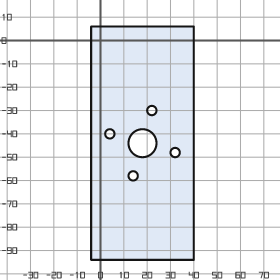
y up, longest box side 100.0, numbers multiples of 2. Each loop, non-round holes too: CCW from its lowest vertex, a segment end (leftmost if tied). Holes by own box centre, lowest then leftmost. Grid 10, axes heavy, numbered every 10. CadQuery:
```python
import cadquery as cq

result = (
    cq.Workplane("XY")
    .moveTo(-4.0, -94.0)
    .lineTo(40.0, -94.0)
    .lineTo(40.0, 6.0)
    .lineTo(-4.0, 6.0)
    .close()
    .moveTo(14.0, -58.0)
    .circle(2.0)
    .moveTo(32.0, -48.0)
    .circle(2.0)
    .moveTo(18.0, -44.0)
    .circle(6.0)
    .moveTo(4.0, -40.0)
    .circle(2.0)
    .moveTo(22.0, -30.0)
    .circle(2.0)
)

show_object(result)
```